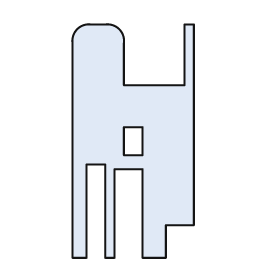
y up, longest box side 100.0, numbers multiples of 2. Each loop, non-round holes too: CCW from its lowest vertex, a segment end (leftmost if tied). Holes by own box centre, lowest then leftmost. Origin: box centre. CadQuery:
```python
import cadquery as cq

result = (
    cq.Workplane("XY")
    .moveTo(-26.0, -50.0)
    .lineTo(-20.0, -50.0)
    .lineTo(-20.0, -10.0)
    .lineTo(-12.0, -10.0)
    .lineTo(-12.0, -50.0)
    .lineTo(-8.0, -50.0)
    .lineTo(-8.0, -12.0)
    .lineTo(4.0, -12.0)
    .lineTo(4.0, -50.0)
    .lineTo(14.0, -50.0)
    .lineTo(14.0, -36.0)
    .lineTo(26.0, -36.0)
    .lineTo(26.0, 50.0)
    .lineTo(22.0, 50.0)
    .lineTo(22.0, 24.0)
    .lineTo(-4.0, 24.0)
    .lineTo(-4.0, 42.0)
    .threePointArc((-6.0, 48.0), (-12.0, 50.0))
    .lineTo(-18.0, 50.0)
    .threePointArc((-24.0, 48.0), (-26.0, 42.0))
    .close()
    .moveTo(-4.0, -6.0)
    .lineTo(4.0, -6.0)
    .lineTo(4.0, 6.0)
    .lineTo(-4.0, 6.0)
    .close()
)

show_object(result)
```